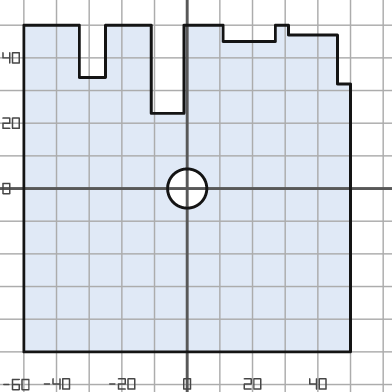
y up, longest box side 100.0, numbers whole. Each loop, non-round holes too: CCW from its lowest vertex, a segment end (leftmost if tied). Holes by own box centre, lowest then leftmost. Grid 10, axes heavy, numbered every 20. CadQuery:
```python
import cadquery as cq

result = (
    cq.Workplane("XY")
    .moveTo(-50.0, -50.0)
    .lineTo(50.0, -50.0)
    .lineTo(50.0, 32.0)
    .lineTo(46.0, 32.0)
    .lineTo(46.0, 47.0)
    .lineTo(31.0, 47.0)
    .lineTo(31.0, 50.0)
    .lineTo(27.0, 50.0)
    .lineTo(27.0, 45.0)
    .lineTo(11.0, 45.0)
    .lineTo(11.0, 50.0)
    .lineTo(-1.0, 50.0)
    .lineTo(-1.0, 23.0)
    .lineTo(-11.0, 23.0)
    .lineTo(-11.0, 50.0)
    .lineTo(-25.0, 50.0)
    .lineTo(-25.0, 34.0)
    .lineTo(-33.0, 34.0)
    .lineTo(-33.0, 50.0)
    .lineTo(-50.0, 50.0)
    .close()
    .moveTo(0.0, 0.0)
    .circle(6.0)
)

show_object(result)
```